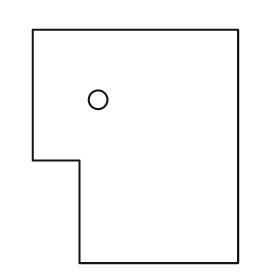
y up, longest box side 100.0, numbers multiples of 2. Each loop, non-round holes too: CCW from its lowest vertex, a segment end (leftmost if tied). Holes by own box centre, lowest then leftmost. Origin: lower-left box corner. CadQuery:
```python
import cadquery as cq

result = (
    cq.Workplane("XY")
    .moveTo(20.0, 0.0)
    .lineTo(88.0, 0.0)
    .lineTo(88.0, 100.0)
    .lineTo(0.0, 100.0)
    .lineTo(0.0, 44.0)
    .lineTo(20.0, 44.0)
    .close()
    .moveTo(28.0, 70.0)
    .circle(4.0)
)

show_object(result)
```